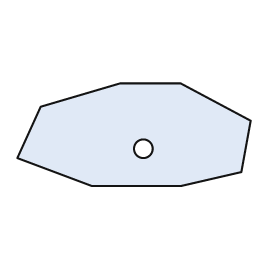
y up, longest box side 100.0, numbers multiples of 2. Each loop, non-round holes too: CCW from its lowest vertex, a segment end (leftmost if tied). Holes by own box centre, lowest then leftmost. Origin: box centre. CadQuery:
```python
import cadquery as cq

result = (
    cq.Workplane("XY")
    .moveTo(-18.0, -22.0)
    .lineTo(20.0, -22.0)
    .lineTo(46.0, -16.0)
    .lineTo(50.0, 6.0)
    .lineTo(20.0, 22.0)
    .lineTo(-6.0, 22.0)
    .lineTo(-40.0, 12.0)
    .lineTo(-50.0, -10.0)
    .close()
    .moveTo(4.0, -6.0)
    .circle(4.0)
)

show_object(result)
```